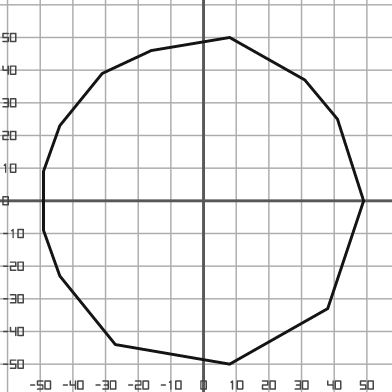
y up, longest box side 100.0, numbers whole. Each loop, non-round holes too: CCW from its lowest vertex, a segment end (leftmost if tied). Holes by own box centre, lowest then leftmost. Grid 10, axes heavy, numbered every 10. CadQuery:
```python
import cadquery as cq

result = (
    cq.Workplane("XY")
    .moveTo(8.0, -50.0)
    .lineTo(38.0, -33.0)
    .lineTo(49.0, 0.0)
    .lineTo(41.0, 25.0)
    .lineTo(31.0, 37.0)
    .lineTo(8.0, 50.0)
    .lineTo(-16.0, 46.0)
    .lineTo(-31.0, 39.0)
    .lineTo(-44.0, 23.0)
    .lineTo(-49.0, 9.0)
    .lineTo(-49.0, -9.0)
    .lineTo(-44.0, -23.0)
    .lineTo(-27.0, -44.0)
    .close()
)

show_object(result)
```